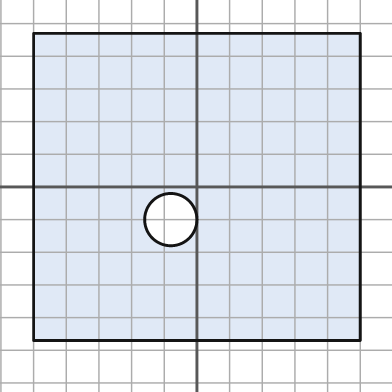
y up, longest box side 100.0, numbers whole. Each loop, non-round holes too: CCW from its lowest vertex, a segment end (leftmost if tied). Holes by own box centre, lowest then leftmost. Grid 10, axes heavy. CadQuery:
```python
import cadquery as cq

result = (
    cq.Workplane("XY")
    .moveTo(-50.0, -47.0)
    .lineTo(50.0, -47.0)
    .lineTo(50.0, 47.0)
    .lineTo(-50.0, 47.0)
    .close()
    .moveTo(-8.0, -10.0)
    .circle(8.0)
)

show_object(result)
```